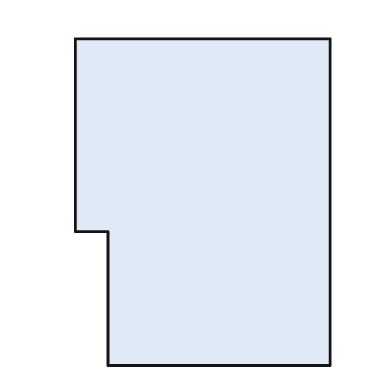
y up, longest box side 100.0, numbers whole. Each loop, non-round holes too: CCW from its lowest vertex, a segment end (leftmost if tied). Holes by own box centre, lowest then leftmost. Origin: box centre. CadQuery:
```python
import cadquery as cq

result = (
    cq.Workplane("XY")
    .moveTo(-29.0, -50.0)
    .lineTo(39.0, -50.0)
    .lineTo(39.0, 50.0)
    .lineTo(-39.0, 50.0)
    .lineTo(-39.0, -9.0)
    .lineTo(-29.0, -9.0)
    .close()
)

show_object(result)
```